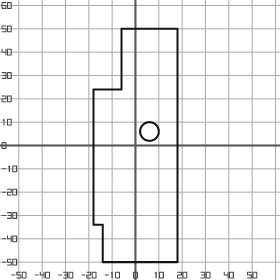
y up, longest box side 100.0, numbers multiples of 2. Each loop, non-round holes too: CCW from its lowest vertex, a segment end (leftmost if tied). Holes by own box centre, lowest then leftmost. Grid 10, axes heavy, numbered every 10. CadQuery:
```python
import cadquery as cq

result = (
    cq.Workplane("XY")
    .moveTo(-14.0, -50.0)
    .lineTo(18.0, -50.0)
    .lineTo(18.0, 50.0)
    .lineTo(-6.0, 50.0)
    .lineTo(-6.0, 24.0)
    .lineTo(-18.0, 24.0)
    .lineTo(-18.0, -34.0)
    .lineTo(-14.0, -34.0)
    .close()
    .moveTo(6.0, 6.0)
    .circle(4.0)
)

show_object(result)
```